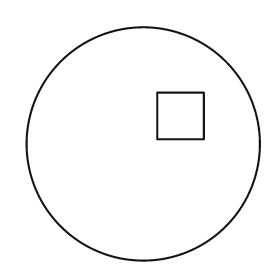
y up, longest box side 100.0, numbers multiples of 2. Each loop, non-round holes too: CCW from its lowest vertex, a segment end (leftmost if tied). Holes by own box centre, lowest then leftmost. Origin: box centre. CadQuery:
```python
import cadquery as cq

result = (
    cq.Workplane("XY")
    .moveTo(0.0, 0.0)
    .circle(50.0)
    .moveTo(6.0, 2.0)
    .lineTo(26.0, 2.0)
    .lineTo(26.0, 22.0)
    .lineTo(6.0, 22.0)
    .close()
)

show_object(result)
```